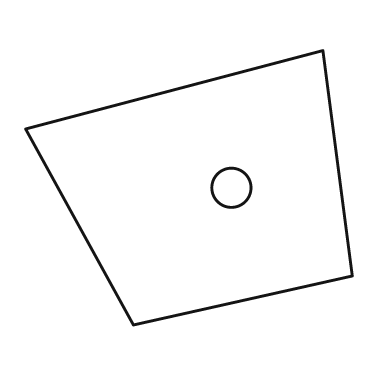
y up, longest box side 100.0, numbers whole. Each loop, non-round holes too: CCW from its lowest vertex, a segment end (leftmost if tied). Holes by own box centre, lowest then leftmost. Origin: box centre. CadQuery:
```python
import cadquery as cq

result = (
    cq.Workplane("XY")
    .moveTo(-17.0, -42.0)
    .lineTo(50.0, -27.0)
    .lineTo(41.0, 42.0)
    .lineTo(-50.0, 18.0)
    .close()
    .moveTo(13.0, 0.0)
    .circle(6.0)
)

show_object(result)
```